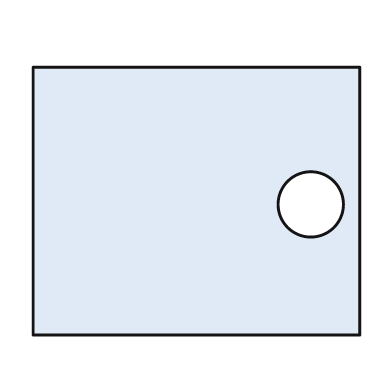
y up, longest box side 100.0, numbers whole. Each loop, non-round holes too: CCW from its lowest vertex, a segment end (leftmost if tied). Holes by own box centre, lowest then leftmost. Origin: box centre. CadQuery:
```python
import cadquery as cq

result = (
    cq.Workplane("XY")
    .moveTo(-50.0, -41.0)
    .lineTo(50.0, -41.0)
    .lineTo(50.0, 41.0)
    .lineTo(-50.0, 41.0)
    .close()
    .moveTo(35.0, -1.0)
    .circle(10.0)
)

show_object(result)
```